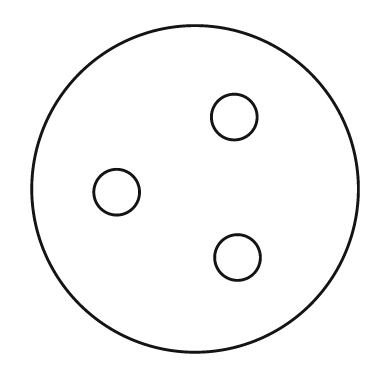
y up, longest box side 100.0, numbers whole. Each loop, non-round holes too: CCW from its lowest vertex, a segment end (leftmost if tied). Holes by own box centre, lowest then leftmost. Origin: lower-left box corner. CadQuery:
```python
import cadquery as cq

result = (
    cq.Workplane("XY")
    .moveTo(50.0, 50.0)
    .circle(50.0)
    .moveTo(63.0, 29.0)
    .circle(7.0)
    .moveTo(26.0, 49.0)
    .circle(7.0)
    .moveTo(62.0, 72.0)
    .circle(7.0)
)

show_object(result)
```